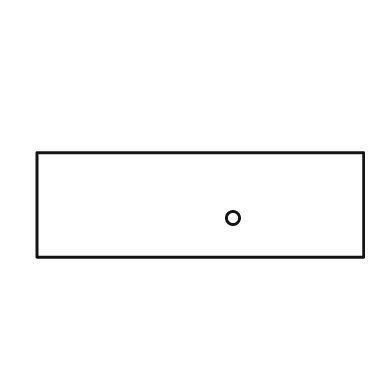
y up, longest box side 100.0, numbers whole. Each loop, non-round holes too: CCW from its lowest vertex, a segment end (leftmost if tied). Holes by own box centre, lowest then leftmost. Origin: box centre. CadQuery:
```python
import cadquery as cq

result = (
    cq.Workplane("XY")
    .moveTo(-50.0, -16.0)
    .lineTo(50.0, -16.0)
    .lineTo(50.0, 16.0)
    .lineTo(-50.0, 16.0)
    .close()
    .moveTo(10.0, -4.0)
    .circle(2.0)
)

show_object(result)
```